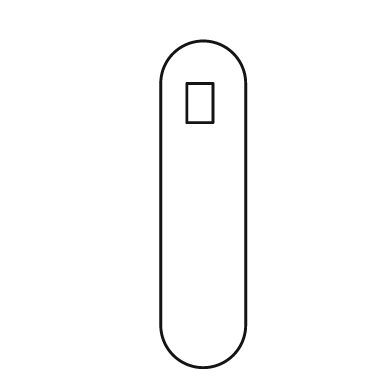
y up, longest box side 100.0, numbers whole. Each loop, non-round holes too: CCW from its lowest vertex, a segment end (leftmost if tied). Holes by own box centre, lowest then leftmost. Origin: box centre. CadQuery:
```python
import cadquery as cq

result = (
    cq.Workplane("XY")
    .moveTo(-13.0, -37.0)
    .threePointArc((0.0, -50.0), (13.0, -37.0))
    .lineTo(13.0, 37.0)
    .threePointArc((0.0, 50.0), (-13.0, 37.0))
    .close()
    .moveTo(-5.0, 25.0)
    .lineTo(3.0, 25.0)
    .lineTo(3.0, 37.0)
    .lineTo(-5.0, 37.0)
    .close()
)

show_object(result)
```